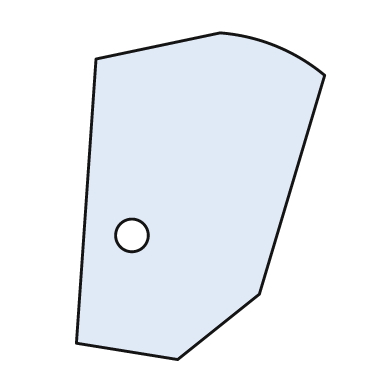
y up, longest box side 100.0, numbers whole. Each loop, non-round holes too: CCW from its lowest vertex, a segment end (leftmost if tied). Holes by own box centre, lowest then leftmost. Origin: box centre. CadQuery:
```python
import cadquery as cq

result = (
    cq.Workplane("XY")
    .moveTo(-7.0, -50.0)
    .lineTo(18.0, -30.0)
    .lineTo(38.0, 37.0)
    .threePointArc((23.0, 46.0), (6.0, 50.0))
    .lineTo(-32.0, 42.0)
    .lineTo(-38.0, -45.0)
    .close()
    .moveTo(-21.0, -12.0)
    .circle(5.0)
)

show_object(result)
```